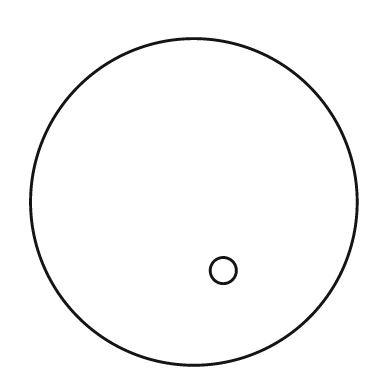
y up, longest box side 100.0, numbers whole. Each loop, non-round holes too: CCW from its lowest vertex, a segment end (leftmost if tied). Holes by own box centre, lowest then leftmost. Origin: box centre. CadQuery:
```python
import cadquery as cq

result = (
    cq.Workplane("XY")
    .moveTo(0.0, 0.0)
    .circle(50.0)
    .moveTo(9.0, -21.0)
    .circle(4.0)
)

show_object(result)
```